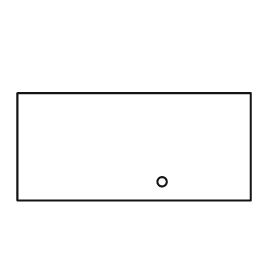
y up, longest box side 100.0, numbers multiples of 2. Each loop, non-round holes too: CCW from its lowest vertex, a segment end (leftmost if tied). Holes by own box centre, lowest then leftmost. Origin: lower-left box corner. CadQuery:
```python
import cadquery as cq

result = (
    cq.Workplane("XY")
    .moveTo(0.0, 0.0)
    .lineTo(100.0, 0.0)
    .lineTo(100.0, 46.0)
    .lineTo(0.0, 46.0)
    .close()
    .moveTo(62.0, 8.0)
    .circle(2.0)
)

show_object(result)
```